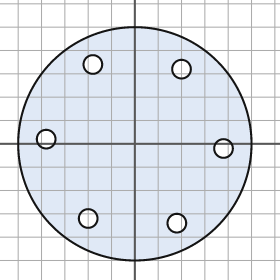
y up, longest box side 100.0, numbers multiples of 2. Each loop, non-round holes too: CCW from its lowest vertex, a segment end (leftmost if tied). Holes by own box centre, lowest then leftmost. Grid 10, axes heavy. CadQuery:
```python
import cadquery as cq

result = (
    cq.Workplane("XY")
    .moveTo(0.0, 0.0)
    .circle(50.0)
    .moveTo(18.0, -34.0)
    .circle(4.0)
    .moveTo(-20.0, -32.0)
    .circle(4.0)
    .moveTo(38.0, -2.0)
    .circle(4.0)
    .moveTo(-38.0, 2.0)
    .circle(4.0)
    .moveTo(20.0, 32.0)
    .circle(4.0)
    .moveTo(-18.0, 34.0)
    .circle(4.0)
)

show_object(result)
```